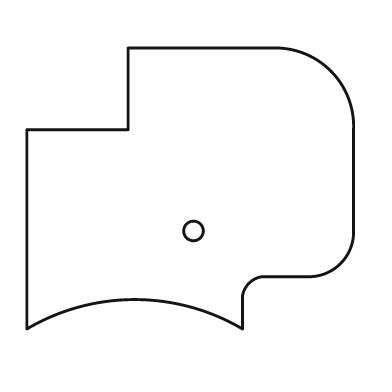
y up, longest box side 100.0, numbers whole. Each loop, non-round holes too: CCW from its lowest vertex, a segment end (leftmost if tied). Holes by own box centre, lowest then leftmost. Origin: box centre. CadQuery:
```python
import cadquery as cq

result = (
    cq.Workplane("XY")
    .moveTo(-50.0, -43.0)
    .threePointArc((-17.0, -34.0), (16.0, -43.0))
    .lineTo(16.0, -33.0)
    .threePointArc((18.0, -29.0), (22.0, -27.0))
    .lineTo(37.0, -27.0)
    .threePointArc((46.0, -23.0), (50.0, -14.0))
    .lineTo(50.0, 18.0)
    .threePointArc((43.0, 36.0), (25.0, 43.0))
    .lineTo(-19.0, 43.0)
    .lineTo(-19.0, 18.0)
    .lineTo(-50.0, 18.0)
    .close()
    .moveTo(1.0, -13.0)
    .circle(3.0)
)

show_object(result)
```